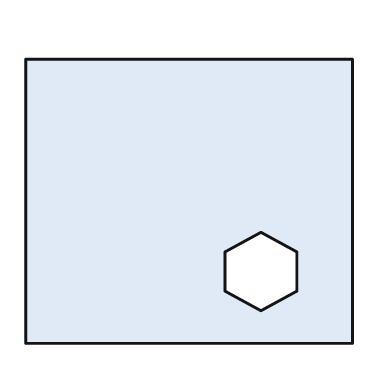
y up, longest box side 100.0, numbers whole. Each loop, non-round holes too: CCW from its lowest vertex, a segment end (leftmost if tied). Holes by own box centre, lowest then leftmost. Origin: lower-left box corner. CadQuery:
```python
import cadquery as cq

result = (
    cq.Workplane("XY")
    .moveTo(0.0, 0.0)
    .lineTo(100.0, 0.0)
    .lineTo(100.0, 87.0)
    .lineTo(0.0, 87.0)
    .close()
    .moveTo(72.0, 10.0)
    .lineTo(83.0, 16.0)
    .lineTo(83.0, 28.0)
    .lineTo(72.0, 34.0)
    .lineTo(61.0, 28.0)
    .lineTo(61.0, 16.0)
    .close()
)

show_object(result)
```